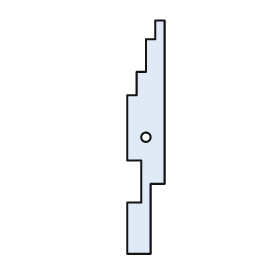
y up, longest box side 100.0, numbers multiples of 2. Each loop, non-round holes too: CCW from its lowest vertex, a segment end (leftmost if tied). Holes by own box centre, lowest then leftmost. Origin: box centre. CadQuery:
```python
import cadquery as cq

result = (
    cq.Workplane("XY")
    .moveTo(-8.0, -50.0)
    .lineTo(2.0, -50.0)
    .lineTo(2.0, -20.0)
    .lineTo(8.0, -20.0)
    .lineTo(8.0, 50.0)
    .lineTo(4.0, 50.0)
    .lineTo(4.0, 42.0)
    .lineTo(0.0, 42.0)
    .lineTo(0.0, 28.0)
    .lineTo(-4.0, 28.0)
    .lineTo(-4.0, 18.0)
    .lineTo(-8.0, 18.0)
    .lineTo(-8.0, -10.0)
    .lineTo(-2.0, -10.0)
    .lineTo(-2.0, -28.0)
    .lineTo(-8.0, -28.0)
    .close()
    .moveTo(0.0, 0.0)
    .circle(2.0)
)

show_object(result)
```